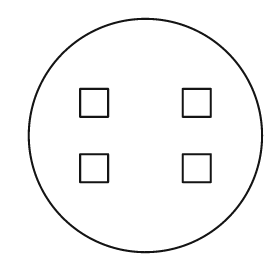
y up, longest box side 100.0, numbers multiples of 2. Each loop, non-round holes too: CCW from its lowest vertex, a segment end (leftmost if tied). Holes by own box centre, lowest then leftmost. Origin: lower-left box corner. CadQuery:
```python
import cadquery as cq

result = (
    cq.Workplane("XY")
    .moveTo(50.0, 50.0)
    .circle(50.0)
    .moveTo(22.0, 30.0)
    .lineTo(34.0, 30.0)
    .lineTo(34.0, 42.0)
    .lineTo(22.0, 42.0)
    .close()
    .moveTo(66.0, 30.0)
    .lineTo(78.0, 30.0)
    .lineTo(78.0, 42.0)
    .lineTo(66.0, 42.0)
    .close()
    .moveTo(22.0, 58.0)
    .lineTo(34.0, 58.0)
    .lineTo(34.0, 70.0)
    .lineTo(22.0, 70.0)
    .close()
    .moveTo(66.0, 58.0)
    .lineTo(78.0, 58.0)
    .lineTo(78.0, 70.0)
    .lineTo(66.0, 70.0)
    .close()
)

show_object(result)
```